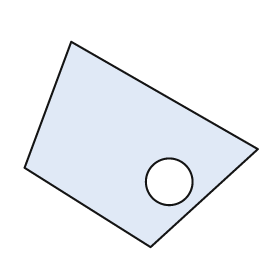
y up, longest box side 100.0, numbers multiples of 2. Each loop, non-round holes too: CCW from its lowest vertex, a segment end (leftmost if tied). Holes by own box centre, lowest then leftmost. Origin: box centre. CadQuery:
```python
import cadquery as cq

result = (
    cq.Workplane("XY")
    .moveTo(4.0, -44.0)
    .lineTo(50.0, -2.0)
    .lineTo(-30.0, 44.0)
    .lineTo(-50.0, -10.0)
    .close()
    .moveTo(12.0, -16.0)
    .circle(10.0)
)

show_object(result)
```